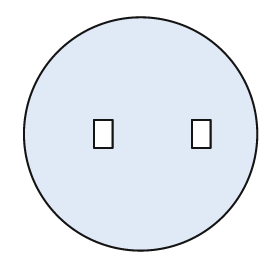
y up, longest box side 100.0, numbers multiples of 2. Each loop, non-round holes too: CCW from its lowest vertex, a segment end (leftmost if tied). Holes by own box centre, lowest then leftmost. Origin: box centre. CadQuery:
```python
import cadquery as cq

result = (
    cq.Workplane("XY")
    .moveTo(0.0, 0.0)
    .circle(50.0)
    .moveTo(-20.0, -6.0)
    .lineTo(-12.0, -6.0)
    .lineTo(-12.0, 6.0)
    .lineTo(-20.0, 6.0)
    .close()
    .moveTo(22.0, -6.0)
    .lineTo(30.0, -6.0)
    .lineTo(30.0, 6.0)
    .lineTo(22.0, 6.0)
    .close()
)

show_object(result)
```